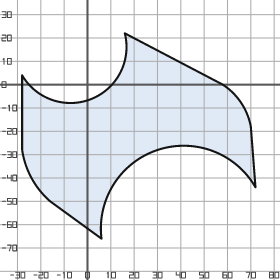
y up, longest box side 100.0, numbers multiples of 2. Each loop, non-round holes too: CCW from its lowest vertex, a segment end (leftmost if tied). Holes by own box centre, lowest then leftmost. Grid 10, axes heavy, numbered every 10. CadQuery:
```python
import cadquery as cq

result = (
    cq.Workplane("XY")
    .moveTo(6.0, -66.0)
    .threePointArc((30.0, -28.0), (72.0, -44.0))
    .lineTo(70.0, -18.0)
    .threePointArc((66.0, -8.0), (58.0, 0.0))
    .lineTo(16.0, 22.0)
    .threePointArc((2.0, -6.0), (-28.0, 4.0))
    .lineTo(-28.0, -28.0)
    .threePointArc((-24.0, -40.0), (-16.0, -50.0))
    .close()
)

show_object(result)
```